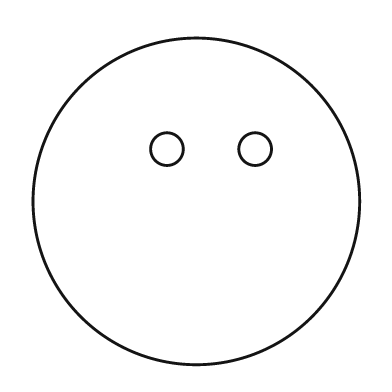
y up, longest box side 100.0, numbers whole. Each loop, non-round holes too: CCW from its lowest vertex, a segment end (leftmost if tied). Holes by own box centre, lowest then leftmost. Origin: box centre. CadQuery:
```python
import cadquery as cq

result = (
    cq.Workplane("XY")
    .moveTo(0.0, 0.0)
    .circle(50.0)
    .moveTo(-9.0, 16.0)
    .circle(5.0)
    .moveTo(18.0, 16.0)
    .circle(5.0)
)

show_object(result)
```